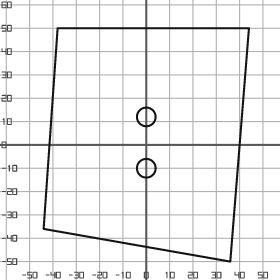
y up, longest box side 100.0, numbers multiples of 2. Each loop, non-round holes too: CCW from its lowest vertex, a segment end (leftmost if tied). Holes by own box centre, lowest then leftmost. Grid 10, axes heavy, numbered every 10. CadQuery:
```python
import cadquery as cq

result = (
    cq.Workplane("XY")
    .moveTo(36.0, -50.0)
    .lineTo(44.0, 50.0)
    .lineTo(-38.0, 50.0)
    .lineTo(-44.0, -36.0)
    .close()
    .moveTo(0.0, -10.0)
    .circle(4.0)
    .moveTo(0.0, 12.0)
    .circle(4.0)
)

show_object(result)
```